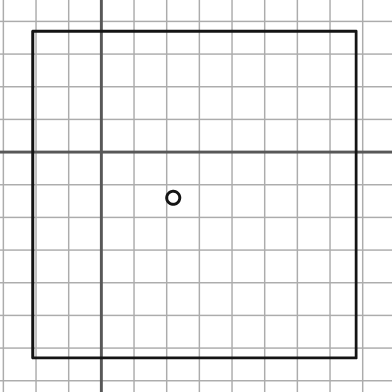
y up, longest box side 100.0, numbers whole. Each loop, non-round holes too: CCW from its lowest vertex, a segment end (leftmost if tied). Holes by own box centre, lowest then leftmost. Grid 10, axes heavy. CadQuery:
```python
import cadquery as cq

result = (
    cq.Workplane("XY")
    .moveTo(-21.0, -63.0)
    .lineTo(78.0, -63.0)
    .lineTo(78.0, 37.0)
    .lineTo(-21.0, 37.0)
    .close()
    .moveTo(22.0, -14.0)
    .circle(2.0)
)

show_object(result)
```